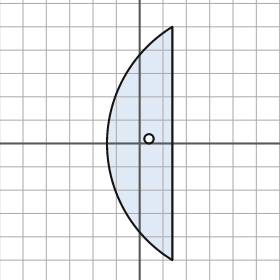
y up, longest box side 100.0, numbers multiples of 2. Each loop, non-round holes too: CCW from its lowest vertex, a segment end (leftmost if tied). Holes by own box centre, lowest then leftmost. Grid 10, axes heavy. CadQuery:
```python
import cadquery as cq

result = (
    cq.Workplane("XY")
    .moveTo(14.0, -50.0)
    .lineTo(14.0, 50.0)
    .threePointArc((-14.0, 0.0), (14.0, -50.0))
    .close()
    .moveTo(4.0, 2.0)
    .circle(2.0)
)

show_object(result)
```